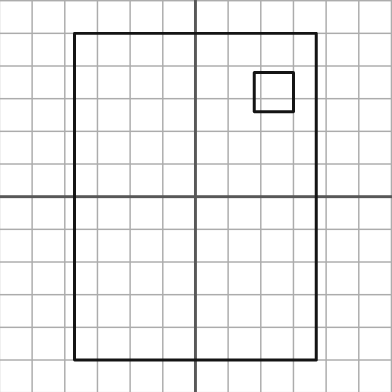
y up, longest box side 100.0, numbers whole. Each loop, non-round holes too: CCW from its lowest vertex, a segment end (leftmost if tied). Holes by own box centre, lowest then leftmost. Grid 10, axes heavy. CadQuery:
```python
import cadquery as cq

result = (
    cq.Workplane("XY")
    .moveTo(-37.0, -50.0)
    .lineTo(37.0, -50.0)
    .lineTo(37.0, 50.0)
    .lineTo(-37.0, 50.0)
    .close()
    .moveTo(18.0, 26.0)
    .lineTo(30.0, 26.0)
    .lineTo(30.0, 38.0)
    .lineTo(18.0, 38.0)
    .close()
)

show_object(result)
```